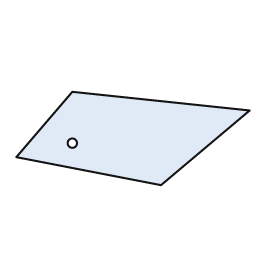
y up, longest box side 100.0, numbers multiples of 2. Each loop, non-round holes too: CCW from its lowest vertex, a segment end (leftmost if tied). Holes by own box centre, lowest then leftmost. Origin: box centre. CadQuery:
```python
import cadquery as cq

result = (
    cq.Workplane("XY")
    .moveTo(12.0, -20.0)
    .lineTo(50.0, 12.0)
    .lineTo(-26.0, 20.0)
    .lineTo(-50.0, -8.0)
    .close()
    .moveTo(-26.0, -2.0)
    .circle(2.0)
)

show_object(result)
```